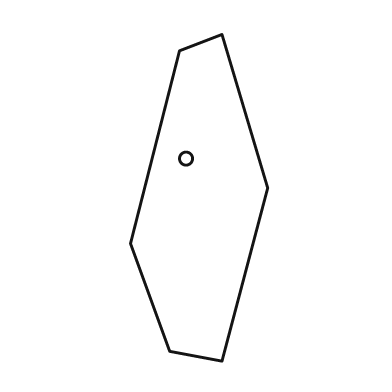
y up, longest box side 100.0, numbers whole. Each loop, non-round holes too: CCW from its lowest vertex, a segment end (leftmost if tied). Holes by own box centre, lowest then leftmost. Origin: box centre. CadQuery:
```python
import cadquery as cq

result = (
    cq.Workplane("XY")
    .moveTo(7.0, -50.0)
    .lineTo(21.0, 3.0)
    .lineTo(7.0, 50.0)
    .lineTo(-6.0, 45.0)
    .lineTo(-21.0, -14.0)
    .lineTo(-9.0, -47.0)
    .close()
    .moveTo(-4.0, 12.0)
    .circle(2.0)
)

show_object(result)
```